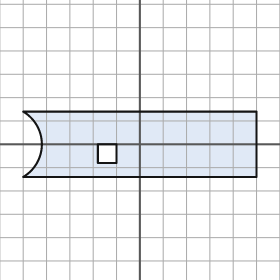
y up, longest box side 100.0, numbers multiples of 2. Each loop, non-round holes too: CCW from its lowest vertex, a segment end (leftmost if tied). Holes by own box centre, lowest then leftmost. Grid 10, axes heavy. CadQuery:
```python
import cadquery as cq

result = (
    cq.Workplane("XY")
    .moveTo(-50.0, -14.0)
    .lineTo(50.0, -14.0)
    .lineTo(50.0, 14.0)
    .lineTo(-50.0, 14.0)
    .threePointArc((-42.0, 0.0), (-50.0, -14.0))
    .close()
    .moveTo(-18.0, -8.0)
    .lineTo(-10.0, -8.0)
    .lineTo(-10.0, 0.0)
    .lineTo(-18.0, 0.0)
    .close()
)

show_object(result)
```